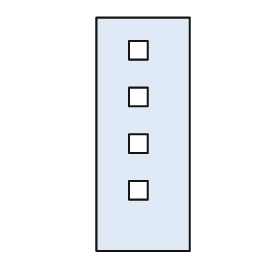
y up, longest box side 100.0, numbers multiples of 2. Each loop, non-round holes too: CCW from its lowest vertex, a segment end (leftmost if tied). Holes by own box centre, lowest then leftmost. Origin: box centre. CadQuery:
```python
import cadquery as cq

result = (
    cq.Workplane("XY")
    .moveTo(-20.0, -50.0)
    .lineTo(20.0, -50.0)
    .lineTo(20.0, 50.0)
    .lineTo(-20.0, 50.0)
    .close()
    .moveTo(-6.0, -28.0)
    .lineTo(2.0, -28.0)
    .lineTo(2.0, -20.0)
    .lineTo(-6.0, -20.0)
    .close()
    .moveTo(-6.0, -8.0)
    .lineTo(2.0, -8.0)
    .lineTo(2.0, 0.0)
    .lineTo(-6.0, 0.0)
    .close()
    .moveTo(-6.0, 12.0)
    .lineTo(2.0, 12.0)
    .lineTo(2.0, 20.0)
    .lineTo(-6.0, 20.0)
    .close()
    .moveTo(-6.0, 32.0)
    .lineTo(2.0, 32.0)
    .lineTo(2.0, 40.0)
    .lineTo(-6.0, 40.0)
    .close()
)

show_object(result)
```